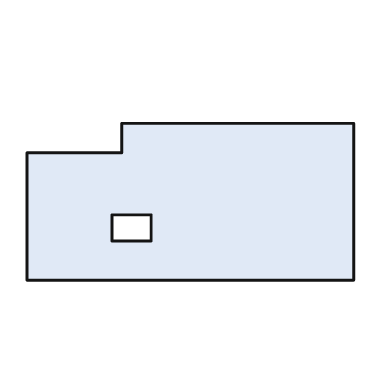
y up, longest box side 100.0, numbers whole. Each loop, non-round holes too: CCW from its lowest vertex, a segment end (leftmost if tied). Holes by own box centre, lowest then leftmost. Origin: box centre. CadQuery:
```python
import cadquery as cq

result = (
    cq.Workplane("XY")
    .moveTo(-50.0, -24.0)
    .lineTo(50.0, -24.0)
    .lineTo(50.0, 24.0)
    .lineTo(-21.0, 24.0)
    .lineTo(-21.0, 15.0)
    .lineTo(-50.0, 15.0)
    .close()
    .moveTo(-24.0, -12.0)
    .lineTo(-12.0, -12.0)
    .lineTo(-12.0, -4.0)
    .lineTo(-24.0, -4.0)
    .close()
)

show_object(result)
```